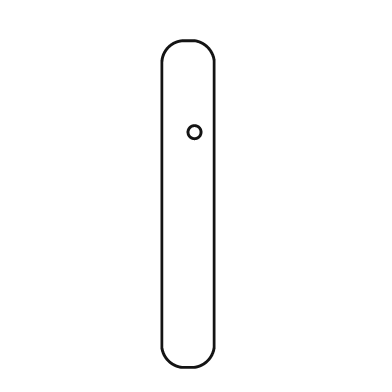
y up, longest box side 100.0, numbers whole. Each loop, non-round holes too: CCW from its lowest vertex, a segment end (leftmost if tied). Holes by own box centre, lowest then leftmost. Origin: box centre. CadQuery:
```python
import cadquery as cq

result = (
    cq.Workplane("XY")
    .moveTo(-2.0, -50.0)
    .lineTo(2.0, -50.0)
    .threePointArc((6.0, -48.0), (8.0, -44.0))
    .lineTo(8.0, 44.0)
    .threePointArc((6.0, 48.0), (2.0, 50.0))
    .lineTo(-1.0, 50.0)
    .threePointArc((-6.0, 48.0), (-8.0, 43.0))
    .lineTo(-8.0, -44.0)
    .threePointArc((-6.0, -48.0), (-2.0, -50.0))
    .close()
    .moveTo(2.0, 22.0)
    .circle(2.0)
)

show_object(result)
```